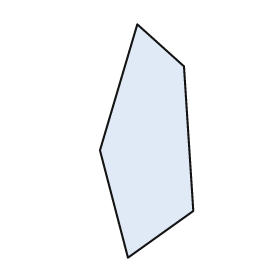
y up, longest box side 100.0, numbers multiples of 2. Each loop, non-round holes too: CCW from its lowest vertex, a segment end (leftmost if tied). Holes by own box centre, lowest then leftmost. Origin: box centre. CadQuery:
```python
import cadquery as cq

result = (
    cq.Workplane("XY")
    .moveTo(-8.0, -50.0)
    .lineTo(20.0, -30.0)
    .lineTo(16.0, 32.0)
    .lineTo(-4.0, 50.0)
    .lineTo(-20.0, -4.0)
    .close()
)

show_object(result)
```